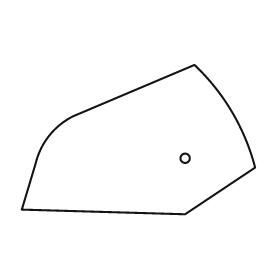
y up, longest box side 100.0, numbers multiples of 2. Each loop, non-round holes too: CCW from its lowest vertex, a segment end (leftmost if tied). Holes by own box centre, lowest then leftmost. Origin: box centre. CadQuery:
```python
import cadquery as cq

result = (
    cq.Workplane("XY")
    .moveTo(20.0, -32.0)
    .lineTo(50.0, -12.0)
    .threePointArc((40.0, 12.0), (24.0, 32.0))
    .lineTo(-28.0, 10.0)
    .threePointArc((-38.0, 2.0), (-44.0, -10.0))
    .lineTo(-50.0, -30.0)
    .close()
    .moveTo(20.0, -8.0)
    .circle(2.0)
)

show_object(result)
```